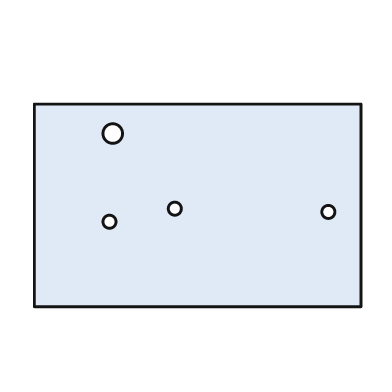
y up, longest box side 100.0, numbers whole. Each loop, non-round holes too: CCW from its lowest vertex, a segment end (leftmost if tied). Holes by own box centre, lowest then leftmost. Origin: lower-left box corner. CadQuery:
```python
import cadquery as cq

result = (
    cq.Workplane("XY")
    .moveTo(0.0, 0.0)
    .lineTo(100.0, 0.0)
    .lineTo(100.0, 62.0)
    .lineTo(0.0, 62.0)
    .close()
    .moveTo(23.0, 26.0)
    .circle(2.0)
    .moveTo(90.0, 29.0)
    .circle(2.0)
    .moveTo(43.0, 30.0)
    .circle(2.0)
    .moveTo(24.0, 53.0)
    .circle(3.0)
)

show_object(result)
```